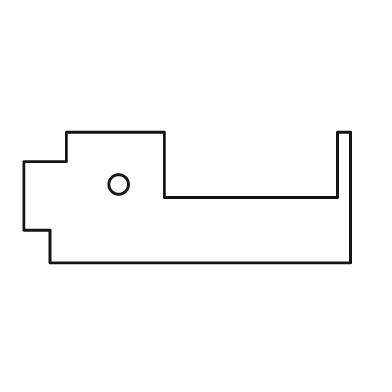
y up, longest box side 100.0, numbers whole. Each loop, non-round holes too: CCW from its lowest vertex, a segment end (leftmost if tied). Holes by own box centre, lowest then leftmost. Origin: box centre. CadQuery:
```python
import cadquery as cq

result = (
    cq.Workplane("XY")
    .moveTo(-42.0, -20.0)
    .lineTo(50.0, -20.0)
    .lineTo(50.0, 20.0)
    .lineTo(46.0, 20.0)
    .lineTo(46.0, 0.0)
    .lineTo(-7.0, 0.0)
    .lineTo(-7.0, 20.0)
    .lineTo(-37.0, 20.0)
    .lineTo(-37.0, 11.0)
    .lineTo(-50.0, 11.0)
    .lineTo(-50.0, -10.0)
    .lineTo(-42.0, -10.0)
    .close()
    .moveTo(-21.0, 4.0)
    .circle(3.0)
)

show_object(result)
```